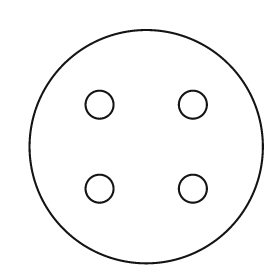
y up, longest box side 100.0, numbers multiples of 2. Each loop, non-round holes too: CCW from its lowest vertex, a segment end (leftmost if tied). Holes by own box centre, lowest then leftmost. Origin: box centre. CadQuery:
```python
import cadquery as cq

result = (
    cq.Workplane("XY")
    .moveTo(0.0, 0.0)
    .circle(50.0)
    .moveTo(-20.0, -18.0)
    .circle(6.0)
    .moveTo(20.0, -18.0)
    .circle(6.0)
    .moveTo(-20.0, 18.0)
    .circle(6.0)
    .moveTo(20.0, 18.0)
    .circle(6.0)
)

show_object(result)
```